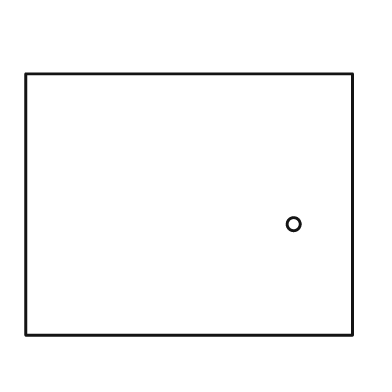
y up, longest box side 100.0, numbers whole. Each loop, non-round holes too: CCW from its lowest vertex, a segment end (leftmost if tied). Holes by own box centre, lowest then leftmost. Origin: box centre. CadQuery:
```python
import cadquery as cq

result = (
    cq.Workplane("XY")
    .moveTo(-50.0, -40.0)
    .lineTo(50.0, -40.0)
    .lineTo(50.0, 40.0)
    .lineTo(-50.0, 40.0)
    .close()
    .moveTo(32.0, -6.0)
    .circle(2.0)
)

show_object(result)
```